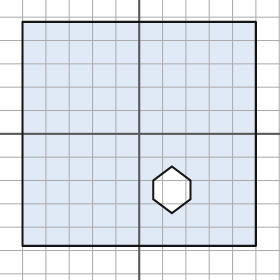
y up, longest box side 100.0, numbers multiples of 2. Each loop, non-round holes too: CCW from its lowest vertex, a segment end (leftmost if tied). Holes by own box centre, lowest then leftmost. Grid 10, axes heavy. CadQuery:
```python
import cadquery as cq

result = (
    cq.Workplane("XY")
    .moveTo(-50.0, -48.0)
    .lineTo(50.0, -48.0)
    .lineTo(50.0, 48.0)
    .lineTo(-50.0, 48.0)
    .close()
    .moveTo(14.0, -34.0)
    .lineTo(22.0, -28.0)
    .lineTo(22.0, -20.0)
    .lineTo(14.0, -14.0)
    .lineTo(6.0, -20.0)
    .lineTo(6.0, -28.0)
    .close()
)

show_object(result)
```